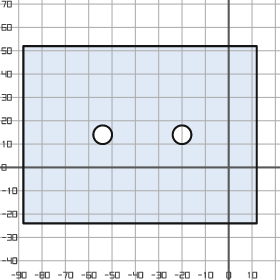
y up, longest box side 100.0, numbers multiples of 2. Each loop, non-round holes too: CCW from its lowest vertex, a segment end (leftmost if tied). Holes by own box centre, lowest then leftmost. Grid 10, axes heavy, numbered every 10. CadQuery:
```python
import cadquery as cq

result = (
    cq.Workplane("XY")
    .moveTo(-88.0, -24.0)
    .lineTo(12.0, -24.0)
    .lineTo(12.0, 52.0)
    .lineTo(-88.0, 52.0)
    .close()
    .moveTo(-54.0, 14.0)
    .circle(4.0)
    .moveTo(-20.0, 14.0)
    .circle(4.0)
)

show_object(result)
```